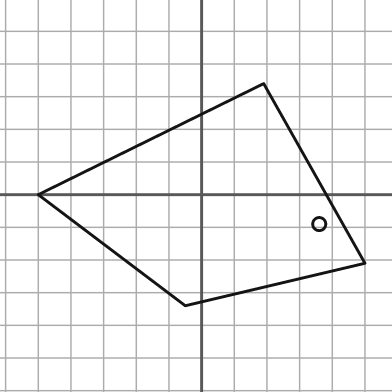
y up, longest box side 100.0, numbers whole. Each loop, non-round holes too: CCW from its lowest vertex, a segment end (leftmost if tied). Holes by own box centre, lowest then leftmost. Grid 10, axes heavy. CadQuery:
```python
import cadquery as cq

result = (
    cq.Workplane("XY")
    .moveTo(-5.0, -34.0)
    .lineTo(50.0, -21.0)
    .lineTo(19.0, 34.0)
    .lineTo(-50.0, 0.0)
    .close()
    .moveTo(36.0, -9.0)
    .circle(2.0)
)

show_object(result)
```